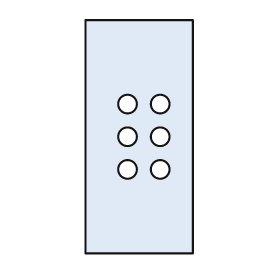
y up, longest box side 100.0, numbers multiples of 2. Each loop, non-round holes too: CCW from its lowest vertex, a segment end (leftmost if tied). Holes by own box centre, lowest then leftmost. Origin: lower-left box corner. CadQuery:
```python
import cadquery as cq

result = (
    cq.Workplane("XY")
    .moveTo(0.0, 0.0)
    .lineTo(46.0, 0.0)
    .lineTo(46.0, 100.0)
    .lineTo(0.0, 100.0)
    .close()
    .moveTo(18.0, 36.0)
    .circle(4.0)
    .moveTo(32.0, 36.0)
    .circle(4.0)
    .moveTo(18.0, 50.0)
    .circle(4.0)
    .moveTo(32.0, 50.0)
    .circle(4.0)
    .moveTo(18.0, 64.0)
    .circle(4.0)
    .moveTo(32.0, 64.0)
    .circle(4.0)
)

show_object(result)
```